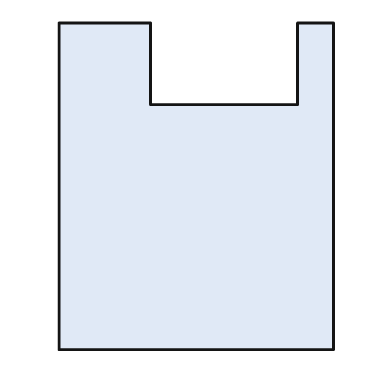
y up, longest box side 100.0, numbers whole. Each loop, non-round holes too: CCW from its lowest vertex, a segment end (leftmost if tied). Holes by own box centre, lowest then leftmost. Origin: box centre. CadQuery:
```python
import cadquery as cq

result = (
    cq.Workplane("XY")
    .moveTo(-42.0, -50.0)
    .lineTo(42.0, -50.0)
    .lineTo(42.0, 50.0)
    .lineTo(31.0, 50.0)
    .lineTo(31.0, 25.0)
    .lineTo(-14.0, 25.0)
    .lineTo(-14.0, 50.0)
    .lineTo(-42.0, 50.0)
    .close()
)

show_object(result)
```